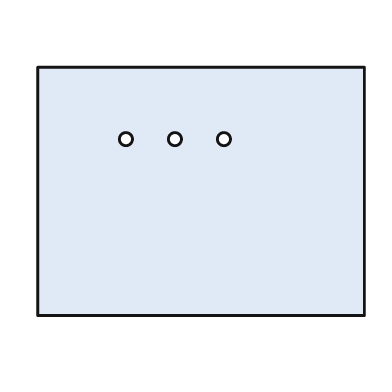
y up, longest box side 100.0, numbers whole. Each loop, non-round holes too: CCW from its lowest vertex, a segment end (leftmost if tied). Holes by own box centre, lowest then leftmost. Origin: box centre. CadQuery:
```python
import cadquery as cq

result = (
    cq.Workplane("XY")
    .moveTo(-50.0, -38.0)
    .lineTo(50.0, -38.0)
    .lineTo(50.0, 38.0)
    .lineTo(-50.0, 38.0)
    .close()
    .moveTo(-23.0, 16.0)
    .circle(2.0)
    .moveTo(-8.0, 16.0)
    .circle(2.0)
    .moveTo(7.0, 16.0)
    .circle(2.0)
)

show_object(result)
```